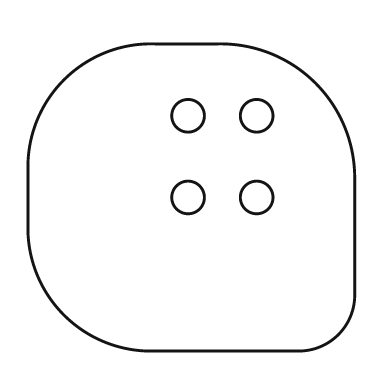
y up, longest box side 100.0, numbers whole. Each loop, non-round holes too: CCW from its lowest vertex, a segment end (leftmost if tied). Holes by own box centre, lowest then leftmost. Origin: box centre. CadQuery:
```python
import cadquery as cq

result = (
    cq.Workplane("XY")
    .moveTo(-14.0, -47.0)
    .lineTo(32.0, -47.0)
    .threePointArc((45.0, -42.0), (50.0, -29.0))
    .lineTo(50.0, 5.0)
    .threePointArc((38.0, 35.0), (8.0, 47.0))
    .lineTo(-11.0, 47.0)
    .threePointArc((-39.0, 36.0), (-50.0, 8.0))
    .lineTo(-50.0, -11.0)
    .threePointArc((-39.0, -36.0), (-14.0, -47.0))
    .close()
    .moveTo(-1.0, 0.0)
    .circle(5.0)
    .moveTo(20.0, 0.0)
    .circle(5.0)
    .moveTo(-1.0, 25.0)
    .circle(5.0)
    .moveTo(20.0, 25.0)
    .circle(5.0)
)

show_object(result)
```